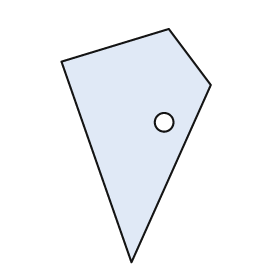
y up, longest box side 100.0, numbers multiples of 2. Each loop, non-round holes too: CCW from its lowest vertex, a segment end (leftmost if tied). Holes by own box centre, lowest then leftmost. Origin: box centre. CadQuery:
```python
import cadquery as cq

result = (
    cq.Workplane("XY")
    .moveTo(-2.0, -50.0)
    .lineTo(32.0, 26.0)
    .lineTo(14.0, 50.0)
    .lineTo(-32.0, 36.0)
    .close()
    .moveTo(12.0, 10.0)
    .circle(4.0)
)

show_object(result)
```